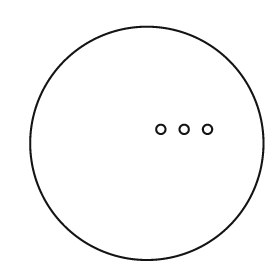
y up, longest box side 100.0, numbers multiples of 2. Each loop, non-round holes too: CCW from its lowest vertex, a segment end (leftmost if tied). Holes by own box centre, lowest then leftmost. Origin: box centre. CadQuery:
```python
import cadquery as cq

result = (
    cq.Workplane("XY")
    .moveTo(0.0, 0.0)
    .circle(50.0)
    .moveTo(6.0, 6.0)
    .circle(2.0)
    .moveTo(16.0, 6.0)
    .circle(2.0)
    .moveTo(26.0, 6.0)
    .circle(2.0)
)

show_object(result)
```